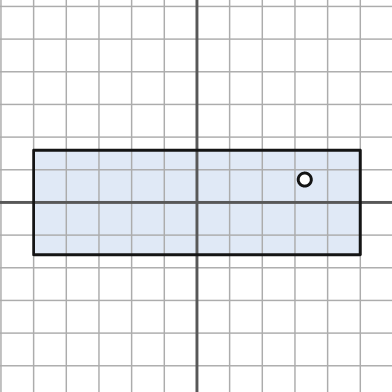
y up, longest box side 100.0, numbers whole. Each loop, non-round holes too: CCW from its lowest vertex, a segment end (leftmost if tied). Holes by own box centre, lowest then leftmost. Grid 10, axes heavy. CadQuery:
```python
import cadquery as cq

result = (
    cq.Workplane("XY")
    .moveTo(-50.0, -16.0)
    .lineTo(50.0, -16.0)
    .lineTo(50.0, 16.0)
    .lineTo(-50.0, 16.0)
    .close()
    .moveTo(33.0, 7.0)
    .circle(2.0)
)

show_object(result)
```